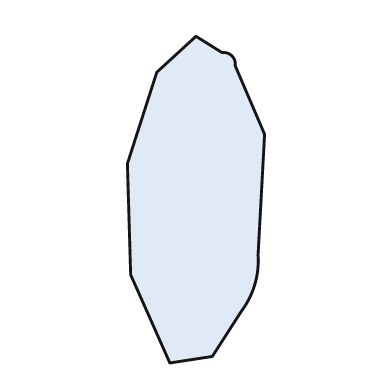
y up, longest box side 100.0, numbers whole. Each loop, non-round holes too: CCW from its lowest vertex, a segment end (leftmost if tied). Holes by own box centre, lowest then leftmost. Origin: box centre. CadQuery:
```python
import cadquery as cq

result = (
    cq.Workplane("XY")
    .moveTo(-8.0, -50.0)
    .lineTo(5.0, -48.0)
    .lineTo(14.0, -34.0)
    .threePointArc((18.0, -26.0), (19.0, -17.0))
    .lineTo(21.0, 20.0)
    .lineTo(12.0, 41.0)
    .threePointArc((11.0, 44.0), (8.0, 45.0))
    .lineTo(0.0, 50.0)
    .lineTo(-12.0, 39.0)
    .lineTo(-21.0, 11.0)
    .lineTo(-20.0, -23.0)
    .close()
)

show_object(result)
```